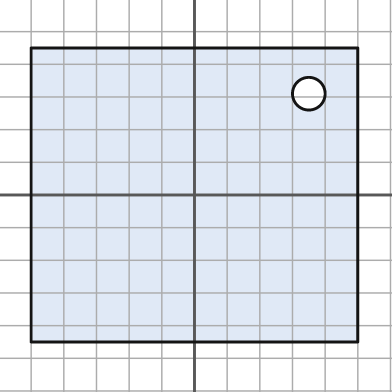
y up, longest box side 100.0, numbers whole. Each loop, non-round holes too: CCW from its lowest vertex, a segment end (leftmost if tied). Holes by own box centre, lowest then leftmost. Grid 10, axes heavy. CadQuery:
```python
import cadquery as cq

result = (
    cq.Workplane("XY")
    .moveTo(-50.0, -45.0)
    .lineTo(50.0, -45.0)
    .lineTo(50.0, 45.0)
    .lineTo(-50.0, 45.0)
    .close()
    .moveTo(35.0, 31.0)
    .circle(5.0)
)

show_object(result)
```